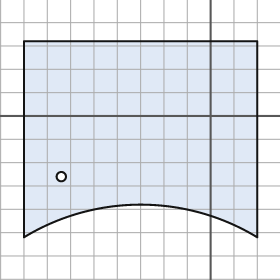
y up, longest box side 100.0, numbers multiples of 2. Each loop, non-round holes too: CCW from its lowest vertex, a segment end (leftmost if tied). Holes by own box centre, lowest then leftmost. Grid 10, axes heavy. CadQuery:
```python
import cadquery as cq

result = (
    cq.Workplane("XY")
    .moveTo(-80.0, -52.0)
    .threePointArc((-30.0, -38.0), (20.0, -52.0))
    .lineTo(20.0, 32.0)
    .lineTo(-80.0, 32.0)
    .close()
    .moveTo(-64.0, -26.0)
    .circle(2.0)
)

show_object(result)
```